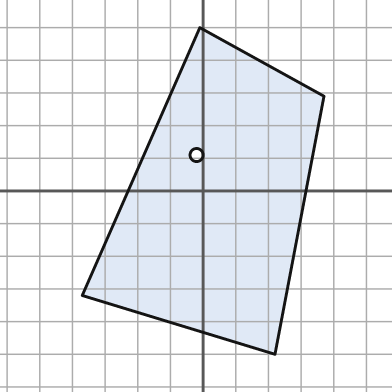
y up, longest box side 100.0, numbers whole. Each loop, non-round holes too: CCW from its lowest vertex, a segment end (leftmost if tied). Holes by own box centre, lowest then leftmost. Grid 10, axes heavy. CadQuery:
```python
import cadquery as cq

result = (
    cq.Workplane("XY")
    .moveTo(22.0, -50.0)
    .lineTo(37.0, 29.0)
    .lineTo(-1.0, 50.0)
    .lineTo(-37.0, -32.0)
    .close()
    .moveTo(-2.0, 11.0)
    .circle(2.0)
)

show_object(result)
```